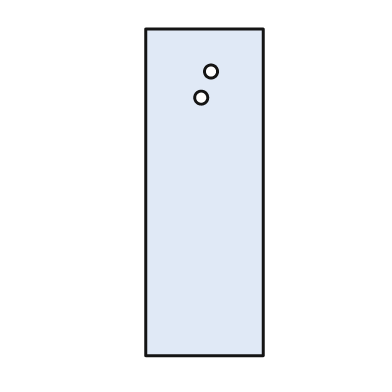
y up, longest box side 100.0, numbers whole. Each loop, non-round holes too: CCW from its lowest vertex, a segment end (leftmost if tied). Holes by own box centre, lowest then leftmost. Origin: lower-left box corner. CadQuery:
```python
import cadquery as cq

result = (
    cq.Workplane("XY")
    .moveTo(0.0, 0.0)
    .lineTo(36.0, 0.0)
    .lineTo(36.0, 100.0)
    .lineTo(0.0, 100.0)
    .close()
    .moveTo(17.0, 79.0)
    .circle(2.0)
    .moveTo(20.0, 87.0)
    .circle(2.0)
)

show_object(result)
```